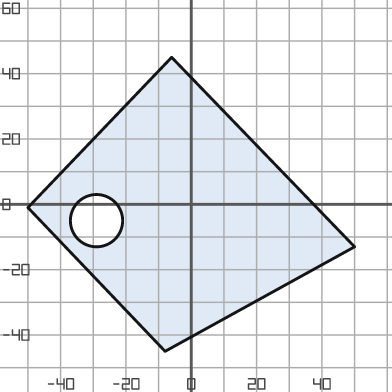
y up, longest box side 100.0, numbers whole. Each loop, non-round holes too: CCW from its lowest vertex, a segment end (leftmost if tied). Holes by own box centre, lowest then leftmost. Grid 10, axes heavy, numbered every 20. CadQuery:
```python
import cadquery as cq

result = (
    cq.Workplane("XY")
    .moveTo(-8.0, -45.0)
    .lineTo(50.0, -13.0)
    .lineTo(-6.0, 45.0)
    .lineTo(-50.0, -1.0)
    .close()
    .moveTo(-29.0, -5.0)
    .circle(8.0)
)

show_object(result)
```